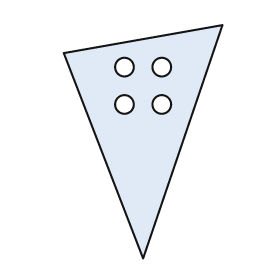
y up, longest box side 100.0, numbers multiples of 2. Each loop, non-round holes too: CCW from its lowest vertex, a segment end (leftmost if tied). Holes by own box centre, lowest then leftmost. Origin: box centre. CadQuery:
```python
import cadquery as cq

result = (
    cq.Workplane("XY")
    .moveTo(0.0, -50.0)
    .lineTo(34.0, 50.0)
    .lineTo(-34.0, 38.0)
    .close()
    .moveTo(-8.0, 16.0)
    .circle(4.0)
    .moveTo(8.0, 16.0)
    .circle(4.0)
    .moveTo(-8.0, 32.0)
    .circle(4.0)
    .moveTo(8.0, 32.0)
    .circle(4.0)
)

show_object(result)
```